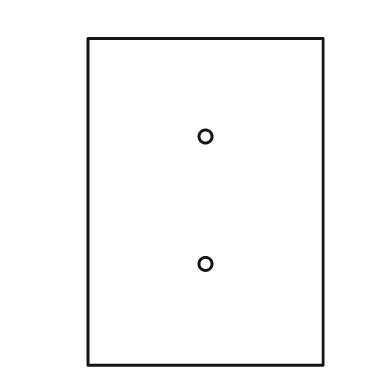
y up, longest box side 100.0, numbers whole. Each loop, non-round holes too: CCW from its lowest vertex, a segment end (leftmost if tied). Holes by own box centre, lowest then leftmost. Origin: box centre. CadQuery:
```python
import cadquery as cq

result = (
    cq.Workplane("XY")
    .moveTo(-36.0, -50.0)
    .lineTo(36.0, -50.0)
    .lineTo(36.0, 50.0)
    .lineTo(-36.0, 50.0)
    .close()
    .moveTo(0.0, -19.0)
    .circle(2.0)
    .moveTo(0.0, 20.0)
    .circle(2.0)
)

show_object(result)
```